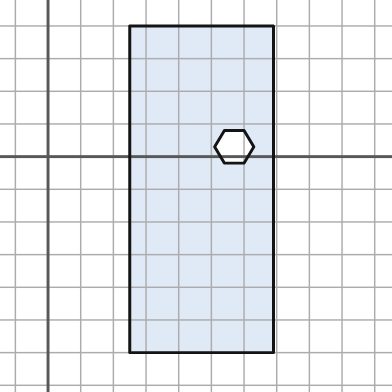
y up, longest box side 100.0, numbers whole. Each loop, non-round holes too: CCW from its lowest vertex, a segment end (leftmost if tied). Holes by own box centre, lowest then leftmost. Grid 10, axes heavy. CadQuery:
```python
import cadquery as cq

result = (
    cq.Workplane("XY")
    .moveTo(25.0, -60.0)
    .lineTo(69.0, -60.0)
    .lineTo(69.0, 40.0)
    .lineTo(25.0, 40.0)
    .close()
    .moveTo(54.0, -2.0)
    .lineTo(60.0, -2.0)
    .lineTo(63.0, 3.0)
    .lineTo(60.0, 8.0)
    .lineTo(54.0, 8.0)
    .lineTo(51.0, 3.0)
    .close()
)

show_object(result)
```